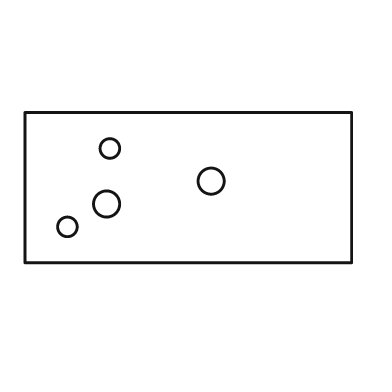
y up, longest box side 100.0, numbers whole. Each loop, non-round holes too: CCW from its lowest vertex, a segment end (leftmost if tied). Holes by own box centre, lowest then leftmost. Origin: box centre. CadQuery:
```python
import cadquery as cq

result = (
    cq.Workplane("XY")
    .moveTo(-50.0, -23.0)
    .lineTo(50.0, -23.0)
    .lineTo(50.0, 23.0)
    .lineTo(-50.0, 23.0)
    .close()
    .moveTo(-37.0, -12.0)
    .circle(3.0)
    .moveTo(-25.0, -5.0)
    .circle(4.0)
    .moveTo(7.0, 2.0)
    .circle(4.0)
    .moveTo(-24.0, 12.0)
    .circle(3.0)
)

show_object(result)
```